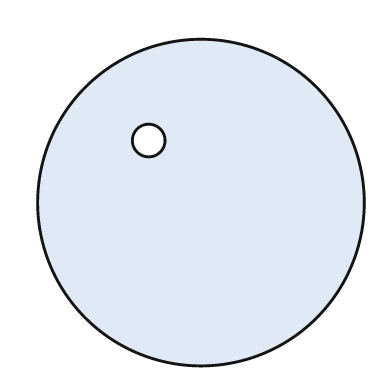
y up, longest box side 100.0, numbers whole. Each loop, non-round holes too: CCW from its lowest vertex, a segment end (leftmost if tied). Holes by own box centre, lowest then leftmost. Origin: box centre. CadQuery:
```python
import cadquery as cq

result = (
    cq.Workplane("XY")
    .moveTo(0.0, 0.0)
    .circle(50.0)
    .moveTo(-16.0, 19.0)
    .circle(5.0)
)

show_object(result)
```